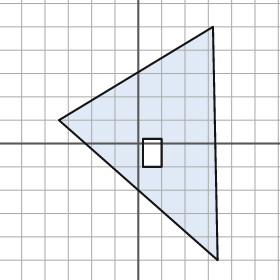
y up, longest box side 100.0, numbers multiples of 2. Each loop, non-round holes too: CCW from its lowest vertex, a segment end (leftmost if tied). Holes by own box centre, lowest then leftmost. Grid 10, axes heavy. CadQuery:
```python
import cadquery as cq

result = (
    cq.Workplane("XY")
    .moveTo(34.0, -50.0)
    .lineTo(32.0, 50.0)
    .lineTo(-34.0, 10.0)
    .close()
    .moveTo(2.0, -10.0)
    .lineTo(10.0, -10.0)
    .lineTo(10.0, 2.0)
    .lineTo(2.0, 2.0)
    .close()
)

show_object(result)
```